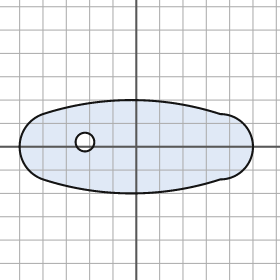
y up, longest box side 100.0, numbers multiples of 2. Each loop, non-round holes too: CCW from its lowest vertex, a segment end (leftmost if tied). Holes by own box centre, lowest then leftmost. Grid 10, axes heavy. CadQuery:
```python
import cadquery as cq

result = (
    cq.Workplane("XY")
    .moveTo(-40.0, -14.0)
    .threePointArc((-2.0, -20.0), (36.0, -14.0))
    .threePointArc((50.0, 0.0), (36.0, 14.0))
    .threePointArc((-2.0, 20.0), (-40.0, 14.0))
    .threePointArc((-50.0, 0.0), (-40.0, -14.0))
    .close()
    .moveTo(-22.0, 2.0)
    .circle(4.0)
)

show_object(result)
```